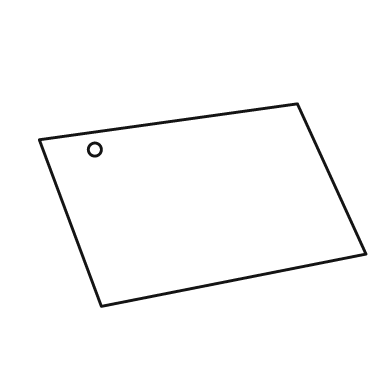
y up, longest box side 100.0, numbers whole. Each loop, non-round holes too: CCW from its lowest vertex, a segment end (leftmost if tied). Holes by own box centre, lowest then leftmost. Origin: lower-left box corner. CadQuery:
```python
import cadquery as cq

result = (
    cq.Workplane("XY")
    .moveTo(19.0, 0.0)
    .lineTo(100.0, 16.0)
    .lineTo(79.0, 62.0)
    .lineTo(0.0, 51.0)
    .close()
    .moveTo(17.0, 48.0)
    .circle(2.0)
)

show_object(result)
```